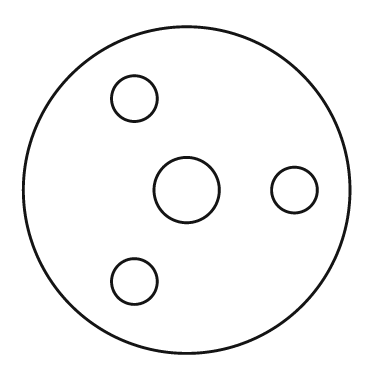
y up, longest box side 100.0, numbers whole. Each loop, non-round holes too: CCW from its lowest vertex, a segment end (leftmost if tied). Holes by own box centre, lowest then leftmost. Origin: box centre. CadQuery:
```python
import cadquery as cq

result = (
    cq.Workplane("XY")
    .moveTo(0.0, 0.0)
    .circle(50.0)
    .moveTo(-16.0, -28.0)
    .circle(7.0)
    .moveTo(0.0, 0.0)
    .circle(10.0)
    .moveTo(33.0, 0.0)
    .circle(7.0)
    .moveTo(-16.0, 28.0)
    .circle(7.0)
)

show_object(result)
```